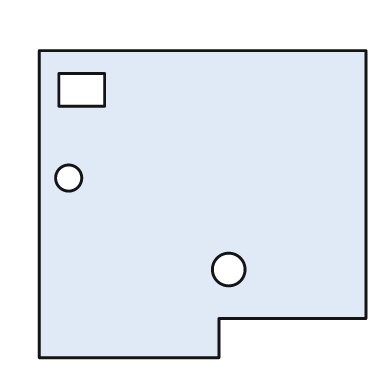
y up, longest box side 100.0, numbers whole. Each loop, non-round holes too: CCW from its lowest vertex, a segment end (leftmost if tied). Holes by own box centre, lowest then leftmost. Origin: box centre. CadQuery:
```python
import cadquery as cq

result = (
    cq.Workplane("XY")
    .moveTo(-50.0, -47.0)
    .lineTo(5.0, -47.0)
    .lineTo(5.0, -35.0)
    .lineTo(50.0, -35.0)
    .lineTo(50.0, 47.0)
    .lineTo(-50.0, 47.0)
    .close()
    .moveTo(8.0, -20.0)
    .circle(5.0)
    .moveTo(-41.0, 8.0)
    .circle(4.0)
    .moveTo(-44.0, 30.0)
    .lineTo(-30.0, 30.0)
    .lineTo(-30.0, 40.0)
    .lineTo(-44.0, 40.0)
    .close()
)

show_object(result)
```